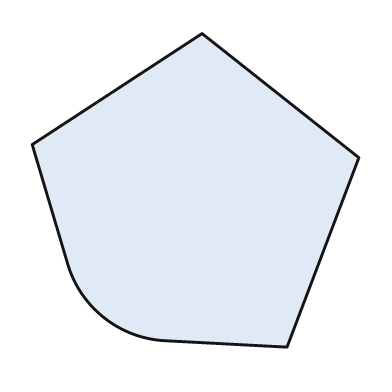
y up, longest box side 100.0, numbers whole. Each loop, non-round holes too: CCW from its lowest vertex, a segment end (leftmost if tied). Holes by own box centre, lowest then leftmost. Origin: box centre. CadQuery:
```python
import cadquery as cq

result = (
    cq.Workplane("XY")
    .moveTo(28.0, -48.0)
    .lineTo(50.0, 10.0)
    .lineTo(2.0, 48.0)
    .lineTo(-50.0, 14.0)
    .lineTo(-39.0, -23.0)
    .threePointArc((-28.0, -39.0), (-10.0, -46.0))
    .close()
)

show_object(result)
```